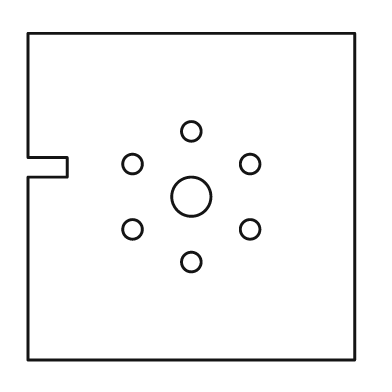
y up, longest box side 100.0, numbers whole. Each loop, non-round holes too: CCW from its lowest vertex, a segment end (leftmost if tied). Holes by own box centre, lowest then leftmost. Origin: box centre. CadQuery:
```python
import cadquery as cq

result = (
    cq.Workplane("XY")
    .moveTo(-50.0, -50.0)
    .lineTo(50.0, -50.0)
    .lineTo(50.0, 50.0)
    .lineTo(-50.0, 50.0)
    .lineTo(-50.0, 12.0)
    .lineTo(-38.0, 12.0)
    .lineTo(-38.0, 6.0)
    .lineTo(-50.0, 6.0)
    .close()
    .moveTo(0.0, -20.0)
    .circle(3.0)
    .moveTo(-18.0, -10.0)
    .circle(3.0)
    .moveTo(18.0, -10.0)
    .circle(3.0)
    .moveTo(0.0, 0.0)
    .circle(6.0)
    .moveTo(-18.0, 10.0)
    .circle(3.0)
    .moveTo(18.0, 10.0)
    .circle(3.0)
    .moveTo(0.0, 20.0)
    .circle(3.0)
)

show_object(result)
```